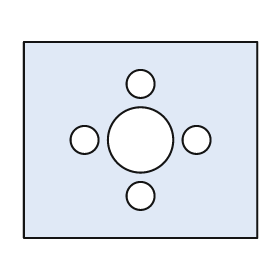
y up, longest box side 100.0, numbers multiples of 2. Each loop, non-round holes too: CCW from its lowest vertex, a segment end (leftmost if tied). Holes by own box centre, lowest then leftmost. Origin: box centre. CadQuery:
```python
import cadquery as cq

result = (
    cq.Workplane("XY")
    .moveTo(-50.0, -42.0)
    .lineTo(50.0, -42.0)
    .lineTo(50.0, 42.0)
    .lineTo(-50.0, 42.0)
    .close()
    .moveTo(0.0, -24.0)
    .circle(6.0)
    .moveTo(-24.0, 0.0)
    .circle(6.0)
    .moveTo(0.0, 0.0)
    .circle(14.0)
    .moveTo(24.0, 0.0)
    .circle(6.0)
    .moveTo(0.0, 24.0)
    .circle(6.0)
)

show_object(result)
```